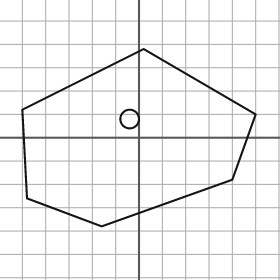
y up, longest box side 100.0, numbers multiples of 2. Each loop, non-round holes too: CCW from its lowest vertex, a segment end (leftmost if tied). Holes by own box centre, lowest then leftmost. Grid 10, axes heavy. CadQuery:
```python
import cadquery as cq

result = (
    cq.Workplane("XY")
    .moveTo(-16.0, -38.0)
    .lineTo(40.0, -18.0)
    .lineTo(50.0, 10.0)
    .lineTo(2.0, 38.0)
    .lineTo(-50.0, 12.0)
    .lineTo(-48.0, -26.0)
    .close()
    .moveTo(-4.0, 8.0)
    .circle(4.0)
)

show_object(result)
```